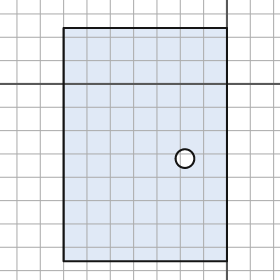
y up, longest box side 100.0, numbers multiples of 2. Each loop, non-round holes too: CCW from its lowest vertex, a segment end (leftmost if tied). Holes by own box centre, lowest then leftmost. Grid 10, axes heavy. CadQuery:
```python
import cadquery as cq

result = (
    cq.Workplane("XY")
    .moveTo(-70.0, -76.0)
    .lineTo(0.0, -76.0)
    .lineTo(0.0, 24.0)
    .lineTo(-70.0, 24.0)
    .close()
    .moveTo(-18.0, -32.0)
    .circle(4.0)
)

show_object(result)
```